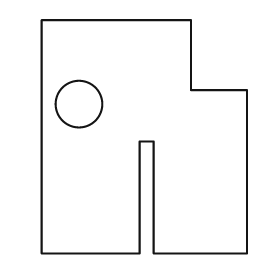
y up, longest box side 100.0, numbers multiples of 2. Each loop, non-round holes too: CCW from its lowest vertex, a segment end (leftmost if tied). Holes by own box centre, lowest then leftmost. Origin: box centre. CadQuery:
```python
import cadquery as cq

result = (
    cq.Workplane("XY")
    .moveTo(-44.0, -50.0)
    .lineTo(-2.0, -50.0)
    .lineTo(-2.0, -2.0)
    .lineTo(4.0, -2.0)
    .lineTo(4.0, -50.0)
    .lineTo(44.0, -50.0)
    .lineTo(44.0, 20.0)
    .lineTo(20.0, 20.0)
    .lineTo(20.0, 50.0)
    .lineTo(-44.0, 50.0)
    .close()
    .moveTo(-28.0, 14.0)
    .circle(10.0)
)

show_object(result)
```